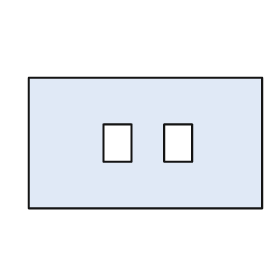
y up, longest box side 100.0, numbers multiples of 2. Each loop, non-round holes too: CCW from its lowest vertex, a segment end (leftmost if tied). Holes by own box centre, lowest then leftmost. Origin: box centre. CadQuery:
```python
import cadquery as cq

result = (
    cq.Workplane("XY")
    .moveTo(-50.0, -28.0)
    .lineTo(50.0, -28.0)
    .lineTo(50.0, 28.0)
    .lineTo(-50.0, 28.0)
    .close()
    .moveTo(-18.0, -8.0)
    .lineTo(-6.0, -8.0)
    .lineTo(-6.0, 8.0)
    .lineTo(-18.0, 8.0)
    .close()
    .moveTo(8.0, -8.0)
    .lineTo(20.0, -8.0)
    .lineTo(20.0, 8.0)
    .lineTo(8.0, 8.0)
    .close()
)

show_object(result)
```